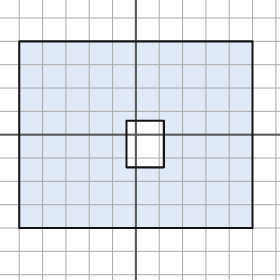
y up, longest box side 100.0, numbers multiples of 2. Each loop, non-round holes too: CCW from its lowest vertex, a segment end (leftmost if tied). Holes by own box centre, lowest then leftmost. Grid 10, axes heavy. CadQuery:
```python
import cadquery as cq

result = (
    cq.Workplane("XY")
    .moveTo(-50.0, -40.0)
    .lineTo(50.0, -40.0)
    .lineTo(50.0, 40.0)
    .lineTo(-50.0, 40.0)
    .close()
    .moveTo(-4.0, -14.0)
    .lineTo(12.0, -14.0)
    .lineTo(12.0, 6.0)
    .lineTo(-4.0, 6.0)
    .close()
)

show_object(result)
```